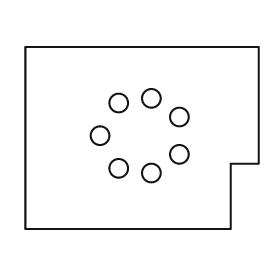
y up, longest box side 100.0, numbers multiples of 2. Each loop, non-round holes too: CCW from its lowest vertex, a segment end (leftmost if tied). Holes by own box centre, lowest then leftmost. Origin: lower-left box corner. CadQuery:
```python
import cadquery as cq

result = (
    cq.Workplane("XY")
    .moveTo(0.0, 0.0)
    .lineTo(88.0, 0.0)
    .lineTo(88.0, 28.0)
    .lineTo(100.0, 28.0)
    .lineTo(100.0, 78.0)
    .lineTo(0.0, 78.0)
    .close()
    .moveTo(54.0, 24.0)
    .circle(4.0)
    .moveTo(40.0, 26.0)
    .circle(4.0)
    .moveTo(66.0, 32.0)
    .circle(4.0)
    .moveTo(32.0, 40.0)
    .circle(4.0)
    .moveTo(66.0, 48.0)
    .circle(4.0)
    .moveTo(40.0, 54.0)
    .circle(4.0)
    .moveTo(54.0, 56.0)
    .circle(4.0)
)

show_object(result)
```